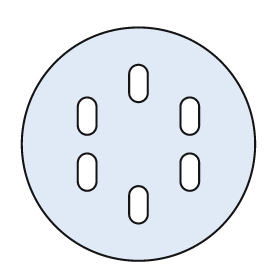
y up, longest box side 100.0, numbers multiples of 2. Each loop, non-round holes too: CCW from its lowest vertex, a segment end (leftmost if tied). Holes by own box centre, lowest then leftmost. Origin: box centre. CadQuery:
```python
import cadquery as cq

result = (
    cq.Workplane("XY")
    .moveTo(0.0, 0.0)
    .circle(50.0)
    .moveTo(-4.0, -30.0)
    .threePointArc((0.0, -34.0), (4.0, -30.0))
    .lineTo(4.0, -22.0)
    .threePointArc((0.0, -18.0), (-4.0, -22.0))
    .close()
    .moveTo(-26.0, -16.0)
    .threePointArc((-22.0, -20.0), (-18.0, -16.0))
    .lineTo(-18.0, -8.0)
    .threePointArc((-22.0, -4.0), (-26.0, -8.0))
    .close()
    .moveTo(18.0, -16.0)
    .threePointArc((22.0, -20.0), (26.0, -16.0))
    .lineTo(26.0, -8.0)
    .threePointArc((22.0, -4.0), (18.0, -8.0))
    .close()
    .moveTo(-26.0, 8.0)
    .threePointArc((-22.0, 4.0), (-18.0, 8.0))
    .lineTo(-18.0, 16.0)
    .threePointArc((-22.0, 20.0), (-26.0, 16.0))
    .close()
    .moveTo(18.0, 8.0)
    .threePointArc((22.0, 4.0), (26.0, 8.0))
    .lineTo(26.0, 16.0)
    .threePointArc((22.0, 20.0), (18.0, 16.0))
    .close()
    .moveTo(-4.0, 22.0)
    .threePointArc((0.0, 18.0), (4.0, 22.0))
    .lineTo(4.0, 30.0)
    .threePointArc((0.0, 34.0), (-4.0, 30.0))
    .close()
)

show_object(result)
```